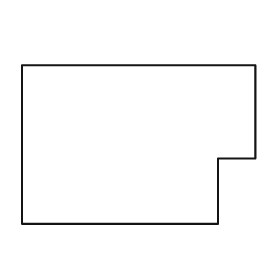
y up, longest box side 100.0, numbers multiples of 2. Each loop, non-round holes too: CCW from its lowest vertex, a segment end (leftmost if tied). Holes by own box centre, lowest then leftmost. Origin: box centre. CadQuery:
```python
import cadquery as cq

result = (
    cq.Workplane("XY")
    .moveTo(-50.0, -34.0)
    .lineTo(34.0, -34.0)
    .lineTo(34.0, -6.0)
    .lineTo(50.0, -6.0)
    .lineTo(50.0, 34.0)
    .lineTo(-50.0, 34.0)
    .close()
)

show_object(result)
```